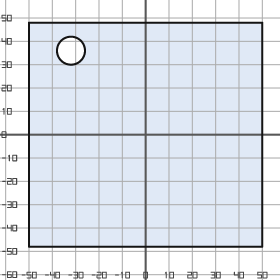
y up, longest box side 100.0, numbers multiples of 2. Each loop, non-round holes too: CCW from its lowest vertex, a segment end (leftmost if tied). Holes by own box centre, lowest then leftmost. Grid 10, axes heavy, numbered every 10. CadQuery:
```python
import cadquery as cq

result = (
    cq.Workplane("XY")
    .moveTo(-50.0, -48.0)
    .lineTo(50.0, -48.0)
    .lineTo(50.0, 48.0)
    .lineTo(-50.0, 48.0)
    .close()
    .moveTo(-32.0, 36.0)
    .circle(6.0)
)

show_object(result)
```